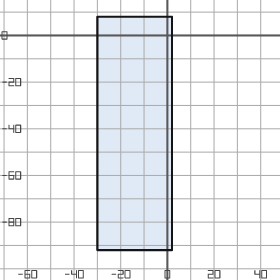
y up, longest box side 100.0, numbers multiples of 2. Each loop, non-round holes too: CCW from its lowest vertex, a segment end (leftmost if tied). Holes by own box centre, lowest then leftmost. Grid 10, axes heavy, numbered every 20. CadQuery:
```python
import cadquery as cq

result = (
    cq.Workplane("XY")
    .moveTo(-30.0, -92.0)
    .lineTo(2.0, -92.0)
    .lineTo(2.0, 8.0)
    .lineTo(-30.0, 8.0)
    .close()
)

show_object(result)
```